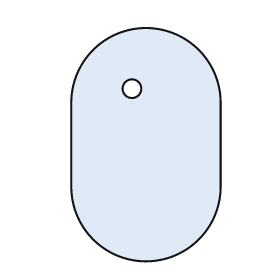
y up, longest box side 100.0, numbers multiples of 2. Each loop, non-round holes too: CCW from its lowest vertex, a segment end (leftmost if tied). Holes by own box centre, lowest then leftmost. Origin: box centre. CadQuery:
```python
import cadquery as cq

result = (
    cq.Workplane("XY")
    .moveTo(-32.0, -18.0)
    .threePointArc((0.0, -50.0), (32.0, -18.0))
    .lineTo(32.0, 18.0)
    .threePointArc((0.0, 50.0), (-32.0, 18.0))
    .close()
    .moveTo(-6.0, 24.0)
    .circle(4.0)
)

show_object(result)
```